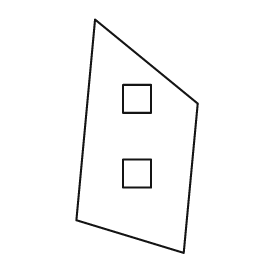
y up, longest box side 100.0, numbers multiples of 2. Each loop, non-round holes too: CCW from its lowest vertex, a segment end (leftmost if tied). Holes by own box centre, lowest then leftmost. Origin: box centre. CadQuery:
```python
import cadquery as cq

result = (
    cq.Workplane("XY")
    .moveTo(20.0, -50.0)
    .lineTo(26.0, 14.0)
    .lineTo(-18.0, 50.0)
    .lineTo(-26.0, -36.0)
    .close()
    .moveTo(-6.0, -22.0)
    .lineTo(6.0, -22.0)
    .lineTo(6.0, -10.0)
    .lineTo(-6.0, -10.0)
    .close()
    .moveTo(-6.0, 10.0)
    .lineTo(6.0, 10.0)
    .lineTo(6.0, 22.0)
    .lineTo(-6.0, 22.0)
    .close()
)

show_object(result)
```